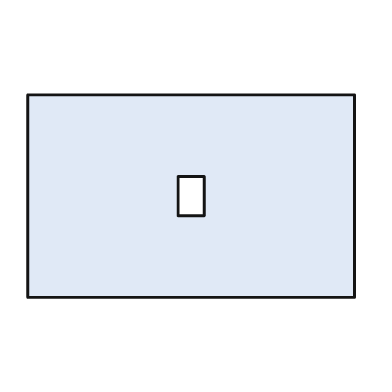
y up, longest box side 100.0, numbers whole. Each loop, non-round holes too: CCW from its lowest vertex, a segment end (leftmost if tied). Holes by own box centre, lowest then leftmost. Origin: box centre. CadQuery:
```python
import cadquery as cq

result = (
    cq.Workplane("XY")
    .moveTo(-50.0, -31.0)
    .lineTo(50.0, -31.0)
    .lineTo(50.0, 31.0)
    .lineTo(-50.0, 31.0)
    .close()
    .moveTo(-4.0, -6.0)
    .lineTo(4.0, -6.0)
    .lineTo(4.0, 6.0)
    .lineTo(-4.0, 6.0)
    .close()
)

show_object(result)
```